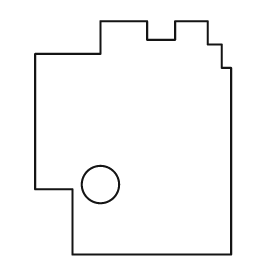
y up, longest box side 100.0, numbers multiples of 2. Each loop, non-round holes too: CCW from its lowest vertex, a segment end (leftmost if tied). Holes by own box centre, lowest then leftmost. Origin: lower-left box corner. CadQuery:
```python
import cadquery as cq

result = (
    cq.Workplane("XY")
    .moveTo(16.0, 0.0)
    .lineTo(84.0, 0.0)
    .lineTo(84.0, 80.0)
    .lineTo(80.0, 80.0)
    .lineTo(80.0, 90.0)
    .lineTo(74.0, 90.0)
    .lineTo(74.0, 100.0)
    .lineTo(60.0, 100.0)
    .lineTo(60.0, 92.0)
    .lineTo(48.0, 92.0)
    .lineTo(48.0, 100.0)
    .lineTo(28.0, 100.0)
    .lineTo(28.0, 86.0)
    .lineTo(0.0, 86.0)
    .lineTo(0.0, 28.0)
    .lineTo(16.0, 28.0)
    .close()
    .moveTo(28.0, 30.0)
    .circle(8.0)
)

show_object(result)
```